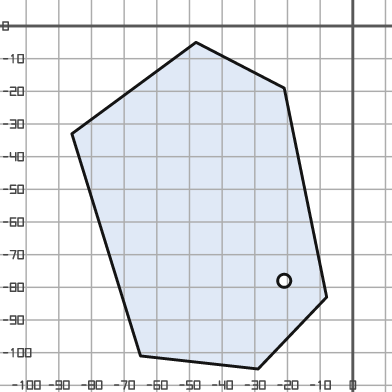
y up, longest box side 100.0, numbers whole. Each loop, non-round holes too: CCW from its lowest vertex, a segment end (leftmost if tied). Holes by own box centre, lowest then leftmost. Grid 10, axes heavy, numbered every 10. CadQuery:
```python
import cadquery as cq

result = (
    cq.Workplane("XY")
    .moveTo(-29.0, -105.0)
    .lineTo(-8.0, -83.0)
    .lineTo(-21.0, -19.0)
    .lineTo(-48.0, -5.0)
    .lineTo(-86.0, -33.0)
    .lineTo(-65.0, -101.0)
    .close()
    .moveTo(-21.0, -78.0)
    .circle(2.0)
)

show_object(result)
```